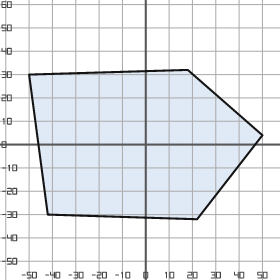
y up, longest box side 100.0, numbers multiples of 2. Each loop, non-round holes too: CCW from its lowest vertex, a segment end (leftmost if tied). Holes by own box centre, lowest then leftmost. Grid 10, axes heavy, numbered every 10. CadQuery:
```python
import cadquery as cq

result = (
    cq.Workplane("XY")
    .moveTo(22.0, -32.0)
    .lineTo(50.0, 4.0)
    .lineTo(18.0, 32.0)
    .lineTo(-50.0, 30.0)
    .lineTo(-42.0, -30.0)
    .close()
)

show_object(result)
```